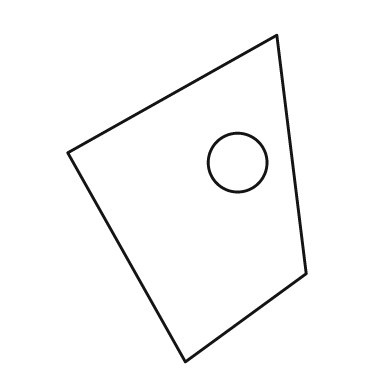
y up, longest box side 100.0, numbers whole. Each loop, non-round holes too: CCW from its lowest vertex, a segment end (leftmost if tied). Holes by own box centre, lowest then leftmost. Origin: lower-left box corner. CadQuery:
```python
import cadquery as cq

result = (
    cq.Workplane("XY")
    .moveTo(36.0, 0.0)
    .lineTo(73.0, 27.0)
    .lineTo(64.0, 100.0)
    .lineTo(0.0, 64.0)
    .close()
    .moveTo(52.0, 61.0)
    .circle(9.0)
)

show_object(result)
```